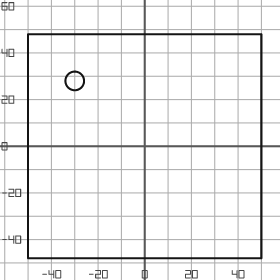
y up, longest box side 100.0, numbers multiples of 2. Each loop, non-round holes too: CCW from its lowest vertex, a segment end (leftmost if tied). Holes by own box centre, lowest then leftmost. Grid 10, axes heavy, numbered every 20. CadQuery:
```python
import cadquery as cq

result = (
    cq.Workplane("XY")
    .moveTo(-50.0, -48.0)
    .lineTo(50.0, -48.0)
    .lineTo(50.0, 48.0)
    .lineTo(-50.0, 48.0)
    .close()
    .moveTo(-30.0, 28.0)
    .circle(4.0)
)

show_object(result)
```